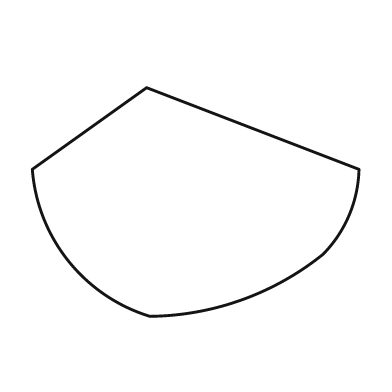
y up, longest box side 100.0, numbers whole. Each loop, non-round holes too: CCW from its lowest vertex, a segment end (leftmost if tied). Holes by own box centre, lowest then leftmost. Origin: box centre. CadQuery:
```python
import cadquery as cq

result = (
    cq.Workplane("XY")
    .moveTo(-14.0, -35.0)
    .threePointArc((14.0, -30.0), (39.0, -16.0))
    .threePointArc((47.0, -4.0), (50.0, 10.0))
    .lineTo(-15.0, 35.0)
    .lineTo(-50.0, 10.0)
    .threePointArc((-39.0, -18.0), (-14.0, -35.0))
    .close()
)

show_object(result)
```